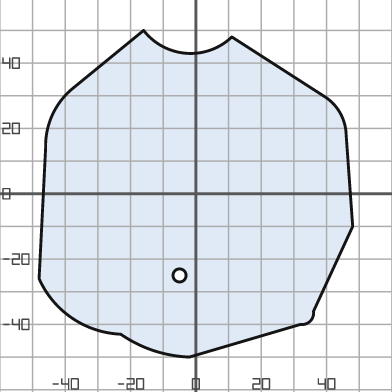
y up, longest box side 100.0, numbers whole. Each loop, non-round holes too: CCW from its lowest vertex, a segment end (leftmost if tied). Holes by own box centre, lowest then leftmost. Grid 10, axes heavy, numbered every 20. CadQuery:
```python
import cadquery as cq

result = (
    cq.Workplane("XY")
    .moveTo(-2.0, -50.0)
    .lineTo(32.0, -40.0)
    .threePointArc((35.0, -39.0), (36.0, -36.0))
    .lineTo(48.0, -10.0)
    .lineTo(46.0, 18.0)
    .threePointArc((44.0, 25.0), (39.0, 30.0))
    .lineTo(11.0, 48.0)
    .threePointArc((-3.0, 43.0), (-16.0, 50.0))
    .lineTo(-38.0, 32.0)
    .threePointArc((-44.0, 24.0), (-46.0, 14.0))
    .lineTo(-48.0, -26.0)
    .threePointArc((-38.0, -38.0), (-23.0, -43.0))
    .threePointArc((-13.0, -48.0), (-2.0, -50.0))
    .close()
    .moveTo(-5.0, -25.0)
    .circle(2.0)
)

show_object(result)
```